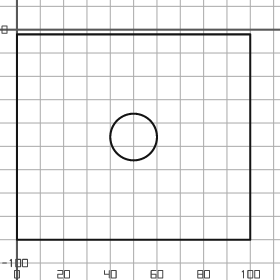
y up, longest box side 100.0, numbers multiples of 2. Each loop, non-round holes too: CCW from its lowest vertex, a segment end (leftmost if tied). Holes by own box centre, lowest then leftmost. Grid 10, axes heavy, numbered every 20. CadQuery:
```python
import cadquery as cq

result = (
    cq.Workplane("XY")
    .moveTo(0.0, -90.0)
    .lineTo(100.0, -90.0)
    .lineTo(100.0, -2.0)
    .lineTo(0.0, -2.0)
    .close()
    .moveTo(50.0, -46.0)
    .circle(10.0)
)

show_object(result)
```